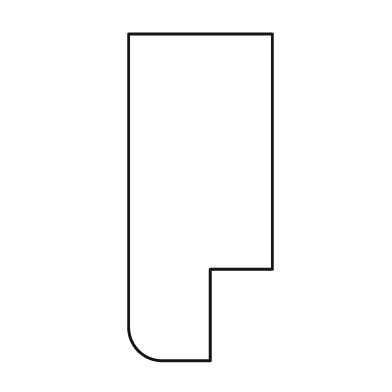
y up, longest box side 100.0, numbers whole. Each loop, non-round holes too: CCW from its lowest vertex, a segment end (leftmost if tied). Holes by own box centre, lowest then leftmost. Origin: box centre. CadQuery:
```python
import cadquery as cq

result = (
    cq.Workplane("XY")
    .moveTo(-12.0, -50.0)
    .lineTo(3.0, -50.0)
    .lineTo(3.0, -22.0)
    .lineTo(22.0, -22.0)
    .lineTo(22.0, 50.0)
    .lineTo(-22.0, 50.0)
    .lineTo(-22.0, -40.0)
    .threePointArc((-19.0, -47.0), (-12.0, -50.0))
    .close()
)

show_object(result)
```